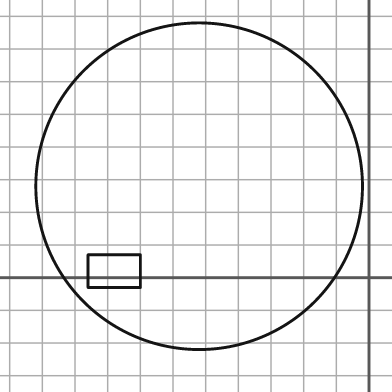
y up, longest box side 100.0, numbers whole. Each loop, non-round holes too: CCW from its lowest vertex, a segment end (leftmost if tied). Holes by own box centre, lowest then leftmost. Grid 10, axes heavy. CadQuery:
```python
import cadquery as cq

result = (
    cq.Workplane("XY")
    .moveTo(-52.0, 28.0)
    .circle(50.0)
    .moveTo(-86.0, -3.0)
    .lineTo(-70.0, -3.0)
    .lineTo(-70.0, 7.0)
    .lineTo(-86.0, 7.0)
    .close()
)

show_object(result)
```